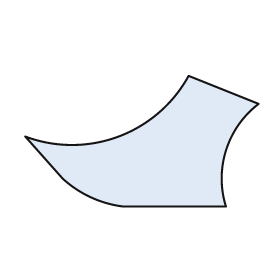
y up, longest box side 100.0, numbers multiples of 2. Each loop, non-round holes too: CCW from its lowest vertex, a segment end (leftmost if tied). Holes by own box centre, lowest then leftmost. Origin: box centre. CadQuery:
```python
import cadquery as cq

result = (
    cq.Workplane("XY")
    .moveTo(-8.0, -28.0)
    .lineTo(36.0, -28.0)
    .threePointArc((36.0, -4.0), (50.0, 16.0))
    .lineTo(20.0, 28.0)
    .threePointArc((-10.0, 2.0), (-50.0, 2.0))
    .lineTo(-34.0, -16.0)
    .threePointArc((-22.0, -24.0), (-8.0, -28.0))
    .close()
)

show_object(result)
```